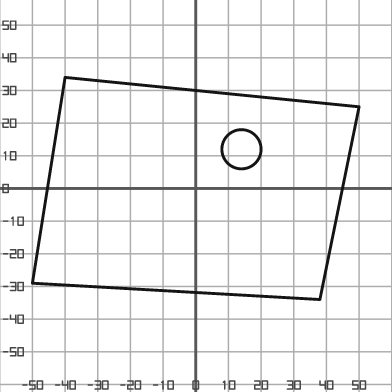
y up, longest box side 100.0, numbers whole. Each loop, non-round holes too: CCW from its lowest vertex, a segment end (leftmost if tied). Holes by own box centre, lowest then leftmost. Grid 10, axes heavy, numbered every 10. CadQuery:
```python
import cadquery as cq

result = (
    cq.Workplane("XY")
    .moveTo(38.0, -34.0)
    .lineTo(50.0, 25.0)
    .lineTo(-40.0, 34.0)
    .lineTo(-50.0, -29.0)
    .close()
    .moveTo(14.0, 12.0)
    .circle(6.0)
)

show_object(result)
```